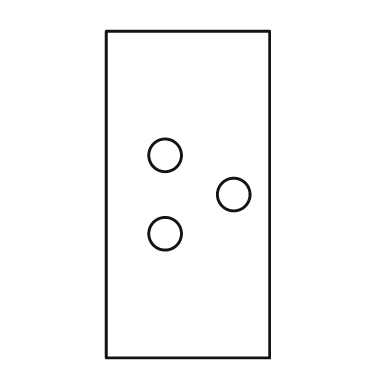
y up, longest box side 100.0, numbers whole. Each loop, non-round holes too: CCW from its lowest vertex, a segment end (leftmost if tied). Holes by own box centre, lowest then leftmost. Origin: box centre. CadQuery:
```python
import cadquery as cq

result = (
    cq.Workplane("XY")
    .moveTo(-25.0, -50.0)
    .lineTo(25.0, -50.0)
    .lineTo(25.0, 50.0)
    .lineTo(-25.0, 50.0)
    .close()
    .moveTo(-7.0, -12.0)
    .circle(5.0)
    .moveTo(14.0, 0.0)
    .circle(5.0)
    .moveTo(-7.0, 12.0)
    .circle(5.0)
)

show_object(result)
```